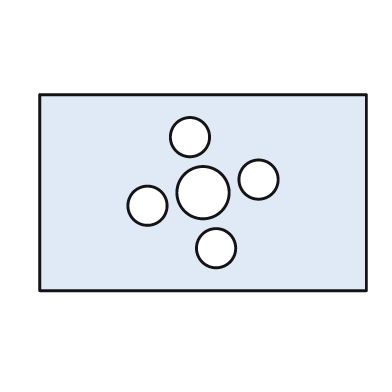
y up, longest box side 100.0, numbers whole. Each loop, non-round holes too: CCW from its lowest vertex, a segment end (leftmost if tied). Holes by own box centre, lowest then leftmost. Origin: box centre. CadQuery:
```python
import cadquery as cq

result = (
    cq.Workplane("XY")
    .moveTo(-50.0, -30.0)
    .lineTo(50.0, -30.0)
    .lineTo(50.0, 30.0)
    .lineTo(-50.0, 30.0)
    .close()
    .moveTo(4.0, -17.0)
    .circle(6.0)
    .moveTo(-17.0, -4.0)
    .circle(6.0)
    .moveTo(0.0, 0.0)
    .circle(8.0)
    .moveTo(17.0, 4.0)
    .circle(6.0)
    .moveTo(-4.0, 17.0)
    .circle(6.0)
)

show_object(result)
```